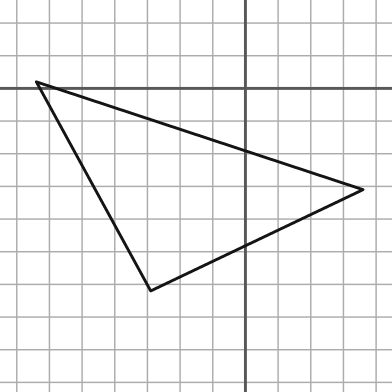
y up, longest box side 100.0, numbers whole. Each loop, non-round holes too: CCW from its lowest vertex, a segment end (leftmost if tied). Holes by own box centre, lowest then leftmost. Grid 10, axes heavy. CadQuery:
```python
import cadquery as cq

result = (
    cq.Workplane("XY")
    .moveTo(-29.0, -62.0)
    .lineTo(36.0, -31.0)
    .lineTo(-64.0, 2.0)
    .close()
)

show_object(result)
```